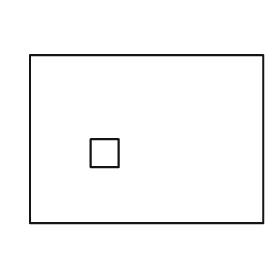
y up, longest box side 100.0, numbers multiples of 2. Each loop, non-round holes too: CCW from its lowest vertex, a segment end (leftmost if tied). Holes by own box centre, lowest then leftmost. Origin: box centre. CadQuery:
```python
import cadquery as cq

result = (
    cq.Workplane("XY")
    .moveTo(-50.0, -36.0)
    .lineTo(50.0, -36.0)
    .lineTo(50.0, 36.0)
    .lineTo(-50.0, 36.0)
    .close()
    .moveTo(-24.0, -12.0)
    .lineTo(-12.0, -12.0)
    .lineTo(-12.0, 0.0)
    .lineTo(-24.0, 0.0)
    .close()
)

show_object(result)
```